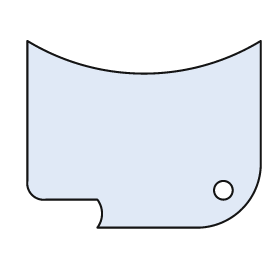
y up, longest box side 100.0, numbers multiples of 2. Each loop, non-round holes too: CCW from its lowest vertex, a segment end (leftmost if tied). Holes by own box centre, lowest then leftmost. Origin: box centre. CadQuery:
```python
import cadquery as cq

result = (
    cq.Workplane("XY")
    .moveTo(-20.0, -40.0)
    .lineTo(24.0, -40.0)
    .threePointArc((42.0, -32.0), (50.0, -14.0))
    .lineTo(50.0, 40.0)
    .threePointArc((0.0, 26.0), (-50.0, 40.0))
    .lineTo(-50.0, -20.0)
    .threePointArc((-48.0, -26.0), (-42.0, -28.0))
    .lineTo(-20.0, -28.0)
    .threePointArc((-18.0, -34.0), (-20.0, -40.0))
    .close()
    .moveTo(34.0, -24.0)
    .circle(4.0)
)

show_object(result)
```